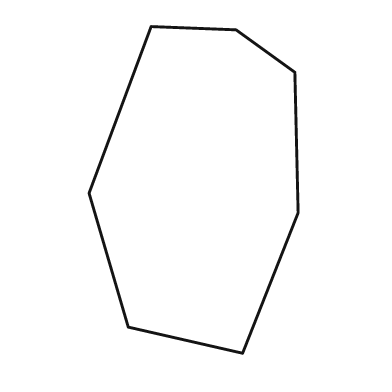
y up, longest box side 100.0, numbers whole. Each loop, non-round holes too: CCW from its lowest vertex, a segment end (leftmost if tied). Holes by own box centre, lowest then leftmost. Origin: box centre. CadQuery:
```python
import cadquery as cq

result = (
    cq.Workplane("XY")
    .moveTo(15.0, -50.0)
    .lineTo(32.0, -7.0)
    .lineTo(31.0, 36.0)
    .lineTo(13.0, 49.0)
    .lineTo(-13.0, 50.0)
    .lineTo(-32.0, -1.0)
    .lineTo(-20.0, -42.0)
    .close()
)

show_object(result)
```